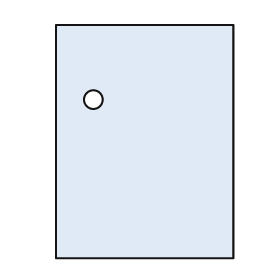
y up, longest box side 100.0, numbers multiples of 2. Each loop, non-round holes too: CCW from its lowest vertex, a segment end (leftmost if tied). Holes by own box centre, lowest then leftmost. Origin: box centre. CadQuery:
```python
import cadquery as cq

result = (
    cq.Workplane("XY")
    .moveTo(-38.0, -50.0)
    .lineTo(38.0, -50.0)
    .lineTo(38.0, 50.0)
    .lineTo(-38.0, 50.0)
    .close()
    .moveTo(-22.0, 18.0)
    .circle(4.0)
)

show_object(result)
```